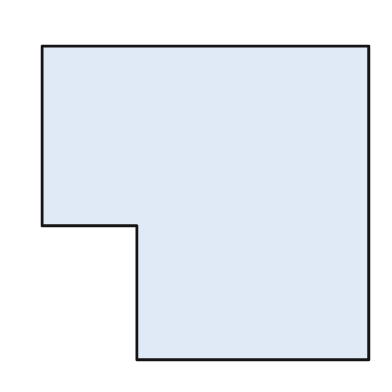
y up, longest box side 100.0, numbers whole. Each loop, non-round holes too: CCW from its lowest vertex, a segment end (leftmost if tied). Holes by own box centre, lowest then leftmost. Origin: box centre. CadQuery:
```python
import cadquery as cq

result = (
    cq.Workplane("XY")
    .moveTo(-21.0, -48.0)
    .lineTo(50.0, -48.0)
    .lineTo(50.0, 48.0)
    .lineTo(-50.0, 48.0)
    .lineTo(-50.0, -7.0)
    .lineTo(-21.0, -7.0)
    .close()
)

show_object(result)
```